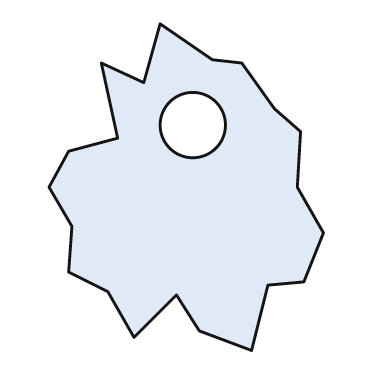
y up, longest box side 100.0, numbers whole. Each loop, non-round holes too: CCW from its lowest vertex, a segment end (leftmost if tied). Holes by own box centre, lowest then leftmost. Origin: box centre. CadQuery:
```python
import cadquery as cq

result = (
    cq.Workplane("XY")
    .moveTo(20.0, -50.0)
    .lineTo(25.0, -30.0)
    .lineTo(36.0, -29.0)
    .lineTo(42.0, -14.0)
    .lineTo(34.0, 0.0)
    .lineTo(35.0, 17.0)
    .lineTo(27.0, 24.0)
    .lineTo(17.0, 38.0)
    .lineTo(8.0, 39.0)
    .lineTo(-8.0, 50.0)
    .lineTo(-13.0, 32.0)
    .lineTo(-26.0, 38.0)
    .lineTo(-21.0, 15.0)
    .lineTo(-36.0, 11.0)
    .lineTo(-42.0, 0.0)
    .lineTo(-35.0, -12.0)
    .lineTo(-36.0, -26.0)
    .lineTo(-24.0, -32.0)
    .lineTo(-16.0, -46.0)
    .lineTo(-3.0, -33.0)
    .lineTo(4.0, -44.0)
    .close()
    .moveTo(2.0, 19.0)
    .circle(10.0)
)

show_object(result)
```